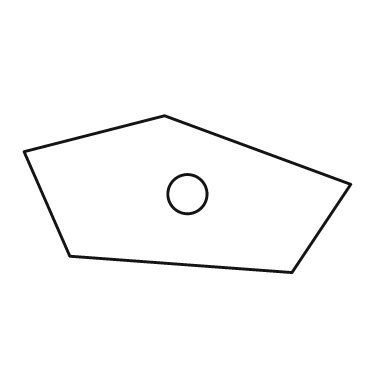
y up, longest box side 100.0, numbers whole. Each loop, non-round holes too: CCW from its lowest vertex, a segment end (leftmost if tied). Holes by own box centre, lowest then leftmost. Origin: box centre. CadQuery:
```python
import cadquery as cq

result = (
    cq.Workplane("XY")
    .moveTo(32.0, -24.0)
    .lineTo(50.0, 3.0)
    .lineTo(-7.0, 24.0)
    .lineTo(-50.0, 13.0)
    .lineTo(-36.0, -19.0)
    .close()
    .moveTo(0.0, 0.0)
    .circle(6.0)
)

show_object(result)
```